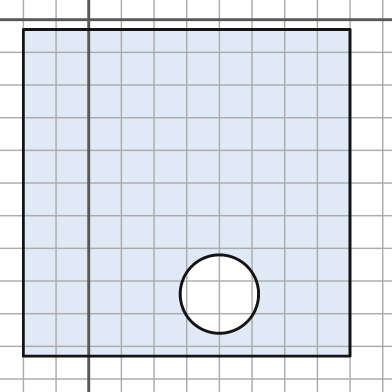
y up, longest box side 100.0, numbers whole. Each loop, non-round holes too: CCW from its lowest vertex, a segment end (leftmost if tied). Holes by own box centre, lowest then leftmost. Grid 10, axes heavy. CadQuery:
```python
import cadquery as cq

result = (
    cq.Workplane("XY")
    .moveTo(-20.0, -103.0)
    .lineTo(80.0, -103.0)
    .lineTo(80.0, -3.0)
    .lineTo(-20.0, -3.0)
    .close()
    .moveTo(40.0, -84.0)
    .circle(12.0)
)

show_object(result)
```